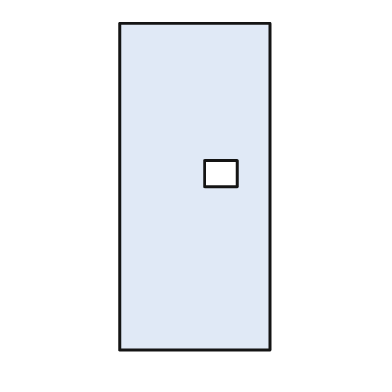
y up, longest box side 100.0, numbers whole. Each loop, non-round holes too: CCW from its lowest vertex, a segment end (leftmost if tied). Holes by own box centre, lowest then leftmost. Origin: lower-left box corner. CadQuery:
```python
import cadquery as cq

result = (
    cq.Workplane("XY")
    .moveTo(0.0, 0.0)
    .lineTo(46.0, 0.0)
    .lineTo(46.0, 100.0)
    .lineTo(0.0, 100.0)
    .close()
    .moveTo(26.0, 50.0)
    .lineTo(36.0, 50.0)
    .lineTo(36.0, 58.0)
    .lineTo(26.0, 58.0)
    .close()
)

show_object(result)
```